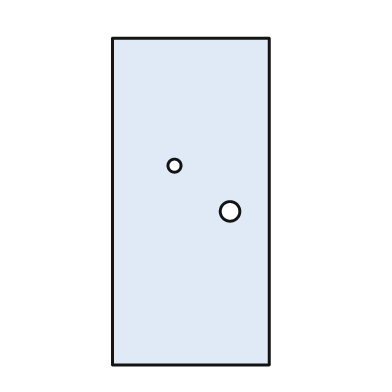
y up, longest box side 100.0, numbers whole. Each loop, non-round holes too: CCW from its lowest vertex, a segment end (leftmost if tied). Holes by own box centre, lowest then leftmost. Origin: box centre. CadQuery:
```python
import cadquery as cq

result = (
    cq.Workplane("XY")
    .moveTo(-24.0, -50.0)
    .lineTo(24.0, -50.0)
    .lineTo(24.0, 50.0)
    .lineTo(-24.0, 50.0)
    .close()
    .moveTo(12.0, -3.0)
    .circle(3.0)
    .moveTo(-5.0, 11.0)
    .circle(2.0)
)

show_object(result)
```